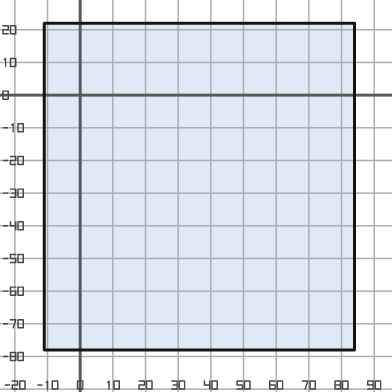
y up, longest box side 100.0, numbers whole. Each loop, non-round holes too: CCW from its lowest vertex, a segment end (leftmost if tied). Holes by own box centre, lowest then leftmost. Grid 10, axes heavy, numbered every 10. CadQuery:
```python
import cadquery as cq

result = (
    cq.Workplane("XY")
    .moveTo(-11.0, -78.0)
    .lineTo(84.0, -78.0)
    .lineTo(84.0, 22.0)
    .lineTo(-11.0, 22.0)
    .close()
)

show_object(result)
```